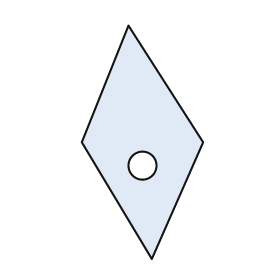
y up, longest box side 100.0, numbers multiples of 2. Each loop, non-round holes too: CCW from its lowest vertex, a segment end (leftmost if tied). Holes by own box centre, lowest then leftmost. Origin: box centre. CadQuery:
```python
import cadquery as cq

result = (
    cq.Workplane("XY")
    .moveTo(4.0, -50.0)
    .lineTo(26.0, 0.0)
    .lineTo(-6.0, 50.0)
    .lineTo(-26.0, 0.0)
    .close()
    .moveTo(0.0, -10.0)
    .circle(6.0)
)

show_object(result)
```